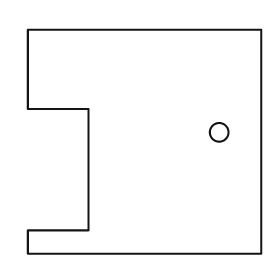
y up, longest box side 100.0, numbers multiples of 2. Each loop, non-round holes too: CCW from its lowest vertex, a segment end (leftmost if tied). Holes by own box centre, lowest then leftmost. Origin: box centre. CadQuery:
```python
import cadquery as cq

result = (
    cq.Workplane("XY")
    .moveTo(-50.0, -48.0)
    .lineTo(50.0, -48.0)
    .lineTo(50.0, 48.0)
    .lineTo(-50.0, 48.0)
    .lineTo(-50.0, 14.0)
    .lineTo(-24.0, 14.0)
    .lineTo(-24.0, -38.0)
    .lineTo(-50.0, -38.0)
    .close()
    .moveTo(32.0, 4.0)
    .circle(4.0)
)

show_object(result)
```